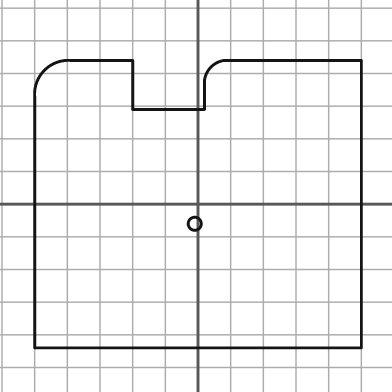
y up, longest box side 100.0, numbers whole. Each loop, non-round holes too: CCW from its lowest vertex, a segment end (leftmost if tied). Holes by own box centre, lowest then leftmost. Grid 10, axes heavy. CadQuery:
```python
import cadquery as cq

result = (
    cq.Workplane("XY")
    .moveTo(-50.0, -44.0)
    .lineTo(50.0, -44.0)
    .lineTo(50.0, 44.0)
    .lineTo(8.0, 44.0)
    .threePointArc((4.0, 42.0), (2.0, 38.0))
    .lineTo(2.0, 29.0)
    .lineTo(-20.0, 29.0)
    .lineTo(-20.0, 44.0)
    .lineTo(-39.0, 44.0)
    .threePointArc((-47.0, 41.0), (-50.0, 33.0))
    .close()
    .moveTo(-1.0, -6.0)
    .circle(2.0)
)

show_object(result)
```